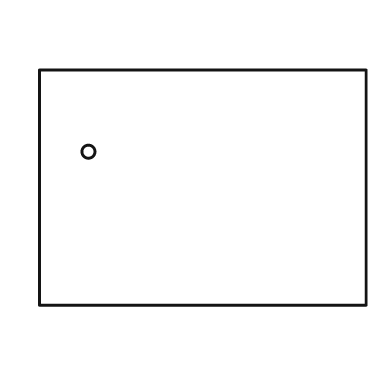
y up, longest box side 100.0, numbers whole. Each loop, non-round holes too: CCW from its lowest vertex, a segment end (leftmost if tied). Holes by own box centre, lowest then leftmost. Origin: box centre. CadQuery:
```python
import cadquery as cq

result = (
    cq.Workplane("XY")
    .moveTo(-50.0, -36.0)
    .lineTo(50.0, -36.0)
    .lineTo(50.0, 36.0)
    .lineTo(-50.0, 36.0)
    .close()
    .moveTo(-35.0, 11.0)
    .circle(2.0)
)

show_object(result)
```